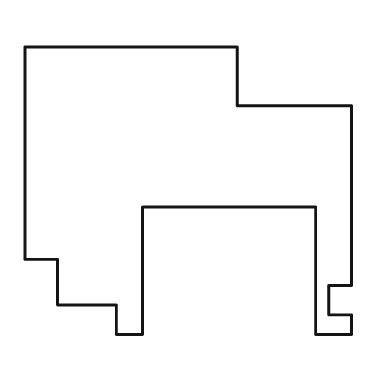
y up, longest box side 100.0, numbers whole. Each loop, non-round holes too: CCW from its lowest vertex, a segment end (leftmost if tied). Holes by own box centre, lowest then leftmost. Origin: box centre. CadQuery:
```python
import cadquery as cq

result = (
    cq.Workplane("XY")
    .moveTo(-22.0, -44.0)
    .lineTo(-14.0, -44.0)
    .lineTo(-14.0, -5.0)
    .lineTo(39.0, -5.0)
    .lineTo(39.0, -44.0)
    .lineTo(50.0, -44.0)
    .lineTo(50.0, -38.0)
    .lineTo(43.0, -38.0)
    .lineTo(43.0, -29.0)
    .lineTo(50.0, -29.0)
    .lineTo(50.0, 26.0)
    .lineTo(15.0, 26.0)
    .lineTo(15.0, 44.0)
    .lineTo(-50.0, 44.0)
    .lineTo(-50.0, -21.0)
    .lineTo(-40.0, -21.0)
    .lineTo(-40.0, -35.0)
    .lineTo(-22.0, -35.0)
    .close()
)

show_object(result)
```